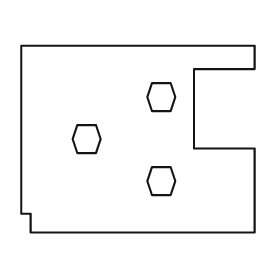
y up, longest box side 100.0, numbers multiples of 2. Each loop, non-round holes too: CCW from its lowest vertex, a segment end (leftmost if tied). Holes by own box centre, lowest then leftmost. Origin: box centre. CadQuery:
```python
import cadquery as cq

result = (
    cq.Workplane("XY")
    .moveTo(-46.0, -40.0)
    .lineTo(50.0, -40.0)
    .lineTo(50.0, -4.0)
    .lineTo(24.0, -4.0)
    .lineTo(24.0, 30.0)
    .lineTo(50.0, 30.0)
    .lineTo(50.0, 40.0)
    .lineTo(-50.0, 40.0)
    .lineTo(-50.0, -32.0)
    .lineTo(-46.0, -32.0)
    .close()
    .moveTo(6.0, -24.0)
    .lineTo(14.0, -24.0)
    .lineTo(16.0, -18.0)
    .lineTo(14.0, -12.0)
    .lineTo(6.0, -12.0)
    .lineTo(4.0, -18.0)
    .close()
    .moveTo(-26.0, -6.0)
    .lineTo(-18.0, -6.0)
    .lineTo(-16.0, 0.0)
    .lineTo(-18.0, 6.0)
    .lineTo(-26.0, 6.0)
    .lineTo(-28.0, 0.0)
    .close()
    .moveTo(6.0, 12.0)
    .lineTo(14.0, 12.0)
    .lineTo(16.0, 18.0)
    .lineTo(14.0, 24.0)
    .lineTo(6.0, 24.0)
    .lineTo(4.0, 18.0)
    .close()
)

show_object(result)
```